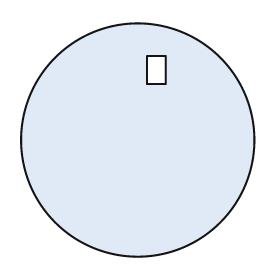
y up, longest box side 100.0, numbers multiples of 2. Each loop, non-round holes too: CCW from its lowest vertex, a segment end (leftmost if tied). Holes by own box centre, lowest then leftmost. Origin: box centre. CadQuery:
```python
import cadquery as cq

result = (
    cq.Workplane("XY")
    .moveTo(0.0, 0.0)
    .circle(50.0)
    .moveTo(4.0, 24.0)
    .lineTo(12.0, 24.0)
    .lineTo(12.0, 36.0)
    .lineTo(4.0, 36.0)
    .close()
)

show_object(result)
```